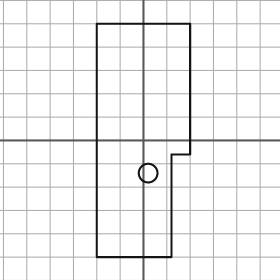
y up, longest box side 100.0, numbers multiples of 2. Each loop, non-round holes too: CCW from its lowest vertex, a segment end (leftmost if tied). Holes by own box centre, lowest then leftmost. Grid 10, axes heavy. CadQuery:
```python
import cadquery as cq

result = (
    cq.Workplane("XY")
    .moveTo(-20.0, -50.0)
    .lineTo(12.0, -50.0)
    .lineTo(12.0, -6.0)
    .lineTo(20.0, -6.0)
    .lineTo(20.0, 50.0)
    .lineTo(-20.0, 50.0)
    .close()
    .moveTo(2.0, -14.0)
    .circle(4.0)
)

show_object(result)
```